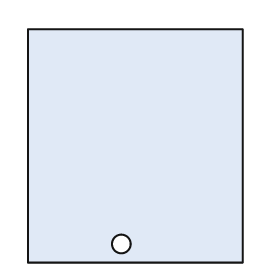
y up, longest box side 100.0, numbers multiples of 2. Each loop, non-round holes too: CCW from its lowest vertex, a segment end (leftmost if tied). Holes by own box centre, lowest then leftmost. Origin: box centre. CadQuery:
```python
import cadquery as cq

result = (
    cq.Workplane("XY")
    .moveTo(-46.0, -50.0)
    .lineTo(46.0, -50.0)
    .lineTo(46.0, 50.0)
    .lineTo(-46.0, 50.0)
    .close()
    .moveTo(-6.0, -42.0)
    .circle(4.0)
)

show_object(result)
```